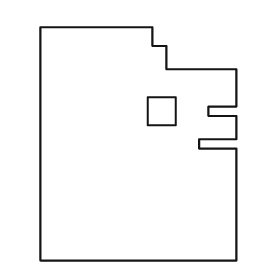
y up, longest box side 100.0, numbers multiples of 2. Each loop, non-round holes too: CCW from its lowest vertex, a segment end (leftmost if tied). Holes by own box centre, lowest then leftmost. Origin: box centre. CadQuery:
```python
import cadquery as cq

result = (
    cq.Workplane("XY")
    .moveTo(-42.0, -50.0)
    .lineTo(42.0, -50.0)
    .lineTo(42.0, -2.0)
    .lineTo(26.0, -2.0)
    .lineTo(26.0, 2.0)
    .lineTo(42.0, 2.0)
    .lineTo(42.0, 12.0)
    .lineTo(30.0, 12.0)
    .lineTo(30.0, 16.0)
    .lineTo(42.0, 16.0)
    .lineTo(42.0, 32.0)
    .lineTo(12.0, 32.0)
    .lineTo(12.0, 42.0)
    .lineTo(6.0, 42.0)
    .lineTo(6.0, 50.0)
    .lineTo(-42.0, 50.0)
    .close()
    .moveTo(4.0, 8.0)
    .lineTo(16.0, 8.0)
    .lineTo(16.0, 20.0)
    .lineTo(4.0, 20.0)
    .close()
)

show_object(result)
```